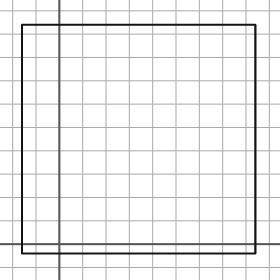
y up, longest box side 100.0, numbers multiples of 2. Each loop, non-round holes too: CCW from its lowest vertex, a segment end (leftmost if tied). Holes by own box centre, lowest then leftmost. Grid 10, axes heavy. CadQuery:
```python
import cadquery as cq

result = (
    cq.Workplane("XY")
    .moveTo(-16.0, -4.0)
    .lineTo(84.0, -4.0)
    .lineTo(84.0, 94.0)
    .lineTo(-16.0, 94.0)
    .close()
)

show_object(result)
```